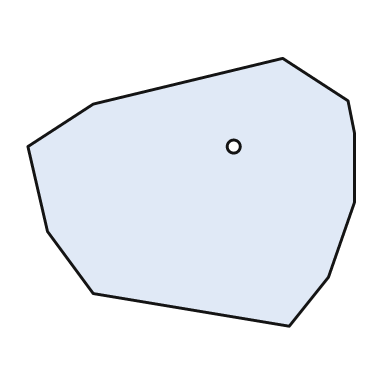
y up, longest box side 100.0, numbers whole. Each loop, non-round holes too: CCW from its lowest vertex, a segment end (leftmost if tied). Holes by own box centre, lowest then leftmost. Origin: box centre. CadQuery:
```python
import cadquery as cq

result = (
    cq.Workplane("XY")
    .moveTo(30.0, -41.0)
    .lineTo(42.0, -26.0)
    .lineTo(50.0, -3.0)
    .lineTo(50.0, 18.0)
    .lineTo(48.0, 28.0)
    .lineTo(28.0, 41.0)
    .lineTo(-30.0, 27.0)
    .lineTo(-50.0, 14.0)
    .lineTo(-44.0, -12.0)
    .lineTo(-30.0, -31.0)
    .close()
    .moveTo(13.0, 14.0)
    .circle(2.0)
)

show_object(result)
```